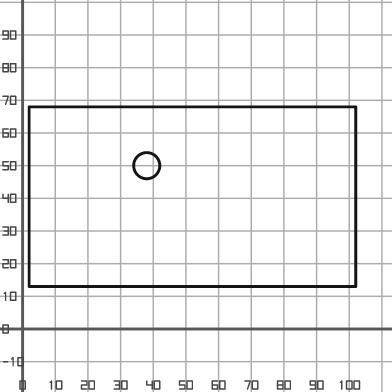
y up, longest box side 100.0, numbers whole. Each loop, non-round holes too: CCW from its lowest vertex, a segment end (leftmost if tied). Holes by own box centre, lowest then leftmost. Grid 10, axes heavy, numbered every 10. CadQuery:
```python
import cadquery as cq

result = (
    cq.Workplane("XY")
    .moveTo(2.0, 13.0)
    .lineTo(102.0, 13.0)
    .lineTo(102.0, 68.0)
    .lineTo(2.0, 68.0)
    .close()
    .moveTo(38.0, 50.0)
    .circle(4.0)
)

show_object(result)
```